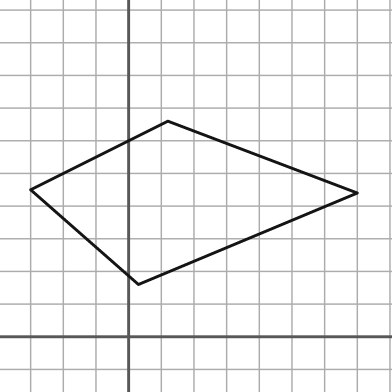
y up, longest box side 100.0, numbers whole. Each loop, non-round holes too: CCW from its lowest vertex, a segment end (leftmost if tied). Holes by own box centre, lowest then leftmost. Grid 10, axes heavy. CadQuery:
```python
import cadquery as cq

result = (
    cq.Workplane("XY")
    .moveTo(3.0, 16.0)
    .lineTo(70.0, 44.0)
    .lineTo(12.0, 66.0)
    .lineTo(-30.0, 45.0)
    .close()
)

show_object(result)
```